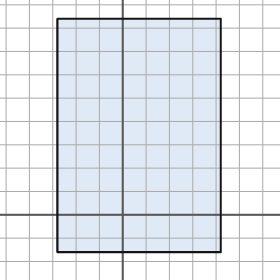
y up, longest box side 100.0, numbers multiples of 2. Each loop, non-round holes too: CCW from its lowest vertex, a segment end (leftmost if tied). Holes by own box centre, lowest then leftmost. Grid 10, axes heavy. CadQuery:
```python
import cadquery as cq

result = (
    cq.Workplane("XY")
    .moveTo(-28.0, -16.0)
    .lineTo(42.0, -16.0)
    .lineTo(42.0, 84.0)
    .lineTo(-28.0, 84.0)
    .close()
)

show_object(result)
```